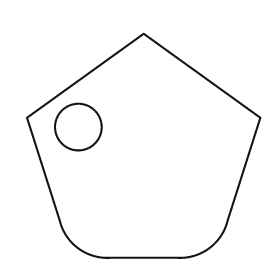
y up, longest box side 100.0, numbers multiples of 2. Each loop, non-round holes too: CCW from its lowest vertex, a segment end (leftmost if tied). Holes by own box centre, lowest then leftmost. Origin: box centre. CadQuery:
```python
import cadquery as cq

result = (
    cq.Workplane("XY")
    .moveTo(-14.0, -48.0)
    .lineTo(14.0, -48.0)
    .threePointArc((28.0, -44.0), (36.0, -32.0))
    .lineTo(50.0, 12.0)
    .lineTo(0.0, 48.0)
    .lineTo(-50.0, 12.0)
    .lineTo(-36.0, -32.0)
    .threePointArc((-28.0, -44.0), (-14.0, -48.0))
    .close()
    .moveTo(-28.0, 8.0)
    .circle(10.0)
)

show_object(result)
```